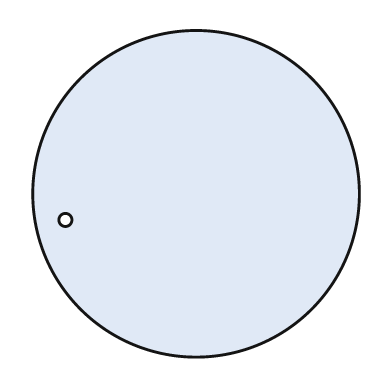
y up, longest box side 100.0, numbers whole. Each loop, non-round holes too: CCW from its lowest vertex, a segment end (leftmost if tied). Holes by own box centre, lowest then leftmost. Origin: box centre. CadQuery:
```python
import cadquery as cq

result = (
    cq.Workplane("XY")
    .moveTo(0.0, 0.0)
    .circle(50.0)
    .moveTo(-40.0, -8.0)
    .circle(2.0)
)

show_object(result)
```